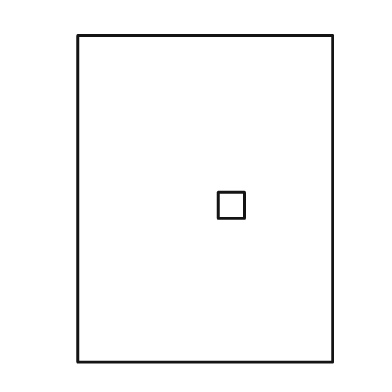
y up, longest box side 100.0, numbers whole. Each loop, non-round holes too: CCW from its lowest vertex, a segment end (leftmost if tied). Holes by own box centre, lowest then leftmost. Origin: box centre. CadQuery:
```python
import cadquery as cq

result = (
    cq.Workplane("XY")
    .moveTo(-39.0, -50.0)
    .lineTo(39.0, -50.0)
    .lineTo(39.0, 50.0)
    .lineTo(-39.0, 50.0)
    .close()
    .moveTo(4.0, -6.0)
    .lineTo(12.0, -6.0)
    .lineTo(12.0, 2.0)
    .lineTo(4.0, 2.0)
    .close()
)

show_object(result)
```